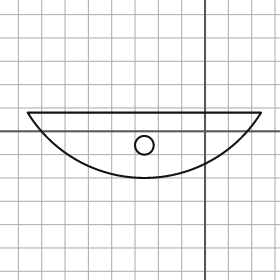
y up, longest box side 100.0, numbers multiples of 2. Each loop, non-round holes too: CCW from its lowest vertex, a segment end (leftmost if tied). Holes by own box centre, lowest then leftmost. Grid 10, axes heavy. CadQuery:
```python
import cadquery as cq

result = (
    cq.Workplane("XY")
    .moveTo(-76.0, 8.0)
    .threePointArc((-26.0, -20.0), (24.0, 8.0))
    .close()
    .moveTo(-26.0, -6.0)
    .circle(4.0)
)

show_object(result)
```